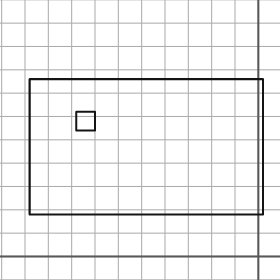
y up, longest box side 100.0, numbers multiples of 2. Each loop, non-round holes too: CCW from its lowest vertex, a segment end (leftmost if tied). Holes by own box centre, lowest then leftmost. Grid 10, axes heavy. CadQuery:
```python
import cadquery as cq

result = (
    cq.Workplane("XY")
    .moveTo(-98.0, 18.0)
    .lineTo(2.0, 18.0)
    .lineTo(2.0, 76.0)
    .lineTo(-98.0, 76.0)
    .close()
    .moveTo(-78.0, 54.0)
    .lineTo(-70.0, 54.0)
    .lineTo(-70.0, 62.0)
    .lineTo(-78.0, 62.0)
    .close()
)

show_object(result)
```